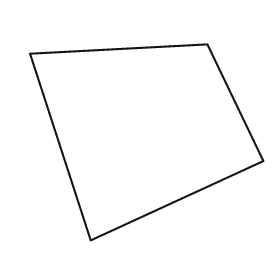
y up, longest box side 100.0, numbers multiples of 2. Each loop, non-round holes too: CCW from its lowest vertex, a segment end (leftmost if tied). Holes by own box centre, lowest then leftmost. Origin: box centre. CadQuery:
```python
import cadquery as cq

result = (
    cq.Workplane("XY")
    .moveTo(-24.0, -42.0)
    .lineTo(50.0, -8.0)
    .lineTo(26.0, 42.0)
    .lineTo(-50.0, 38.0)
    .close()
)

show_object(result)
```